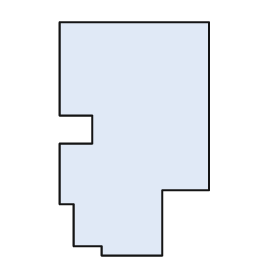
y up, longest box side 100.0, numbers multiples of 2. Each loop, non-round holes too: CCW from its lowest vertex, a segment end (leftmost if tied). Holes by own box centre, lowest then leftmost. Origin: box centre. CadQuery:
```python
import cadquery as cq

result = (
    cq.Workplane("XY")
    .moveTo(-14.0, -50.0)
    .lineTo(12.0, -50.0)
    .lineTo(12.0, -22.0)
    .lineTo(32.0, -22.0)
    .lineTo(32.0, 50.0)
    .lineTo(-32.0, 50.0)
    .lineTo(-32.0, 10.0)
    .lineTo(-18.0, 10.0)
    .lineTo(-18.0, -2.0)
    .lineTo(-32.0, -2.0)
    .lineTo(-32.0, -28.0)
    .lineTo(-26.0, -28.0)
    .lineTo(-26.0, -46.0)
    .lineTo(-14.0, -46.0)
    .close()
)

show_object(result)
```